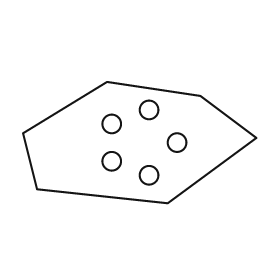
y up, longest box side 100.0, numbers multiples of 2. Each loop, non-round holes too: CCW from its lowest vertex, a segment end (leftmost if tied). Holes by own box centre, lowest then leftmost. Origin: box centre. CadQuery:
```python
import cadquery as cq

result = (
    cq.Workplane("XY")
    .moveTo(12.0, -26.0)
    .lineTo(50.0, 2.0)
    .lineTo(26.0, 20.0)
    .lineTo(-14.0, 26.0)
    .lineTo(-50.0, 4.0)
    .lineTo(-44.0, -20.0)
    .close()
    .moveTo(4.0, -14.0)
    .circle(4.0)
    .moveTo(-12.0, -8.0)
    .circle(4.0)
    .moveTo(16.0, 0.0)
    .circle(4.0)
    .moveTo(-12.0, 8.0)
    .circle(4.0)
    .moveTo(4.0, 14.0)
    .circle(4.0)
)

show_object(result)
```